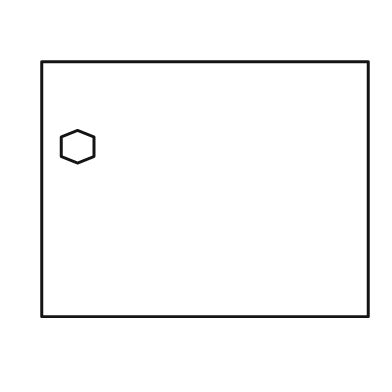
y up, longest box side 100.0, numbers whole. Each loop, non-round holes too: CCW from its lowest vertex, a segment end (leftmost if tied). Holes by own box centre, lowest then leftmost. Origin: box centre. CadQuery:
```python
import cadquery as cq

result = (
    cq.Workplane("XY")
    .moveTo(-50.0, -39.0)
    .lineTo(50.0, -39.0)
    .lineTo(50.0, 39.0)
    .lineTo(-50.0, 39.0)
    .close()
    .moveTo(-39.0, 8.0)
    .lineTo(-34.0, 10.0)
    .lineTo(-34.0, 16.0)
    .lineTo(-39.0, 18.0)
    .lineTo(-44.0, 16.0)
    .lineTo(-44.0, 10.0)
    .close()
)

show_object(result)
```